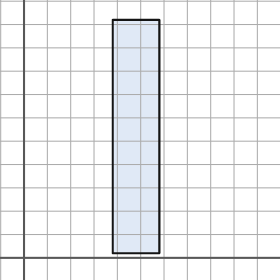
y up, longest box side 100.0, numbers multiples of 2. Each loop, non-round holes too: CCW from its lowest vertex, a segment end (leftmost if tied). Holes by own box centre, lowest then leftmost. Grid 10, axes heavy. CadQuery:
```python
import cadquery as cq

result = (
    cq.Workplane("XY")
    .moveTo(38.0, 2.0)
    .lineTo(58.0, 2.0)
    .lineTo(58.0, 102.0)
    .lineTo(38.0, 102.0)
    .close()
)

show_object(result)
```